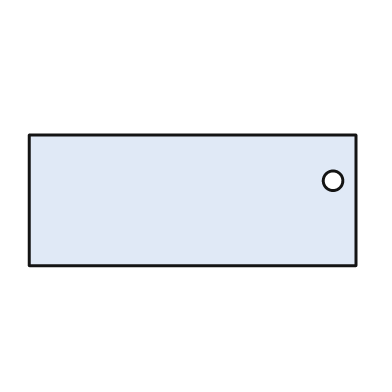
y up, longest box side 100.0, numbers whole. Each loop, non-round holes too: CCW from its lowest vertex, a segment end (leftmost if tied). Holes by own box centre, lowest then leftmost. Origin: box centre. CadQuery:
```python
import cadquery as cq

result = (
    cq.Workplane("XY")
    .moveTo(-50.0, -20.0)
    .lineTo(50.0, -20.0)
    .lineTo(50.0, 20.0)
    .lineTo(-50.0, 20.0)
    .close()
    .moveTo(43.0, 6.0)
    .circle(3.0)
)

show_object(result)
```